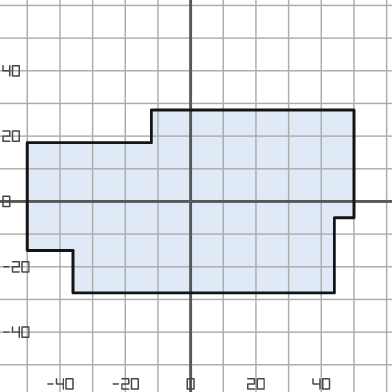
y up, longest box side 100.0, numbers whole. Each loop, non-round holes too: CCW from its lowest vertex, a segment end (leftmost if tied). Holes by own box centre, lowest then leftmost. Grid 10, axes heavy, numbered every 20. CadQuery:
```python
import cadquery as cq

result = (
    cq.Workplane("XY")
    .moveTo(-36.0, -28.0)
    .lineTo(44.0, -28.0)
    .lineTo(44.0, -5.0)
    .lineTo(50.0, -5.0)
    .lineTo(50.0, 28.0)
    .lineTo(-12.0, 28.0)
    .lineTo(-12.0, 18.0)
    .lineTo(-50.0, 18.0)
    .lineTo(-50.0, -15.0)
    .lineTo(-36.0, -15.0)
    .close()
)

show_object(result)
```